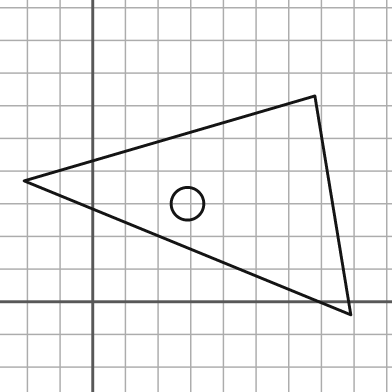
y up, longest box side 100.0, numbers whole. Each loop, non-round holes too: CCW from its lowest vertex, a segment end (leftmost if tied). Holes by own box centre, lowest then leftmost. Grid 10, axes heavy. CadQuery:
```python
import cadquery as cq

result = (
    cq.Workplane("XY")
    .moveTo(79.0, -4.0)
    .lineTo(68.0, 63.0)
    .lineTo(-21.0, 37.0)
    .close()
    .moveTo(29.0, 30.0)
    .circle(5.0)
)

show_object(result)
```